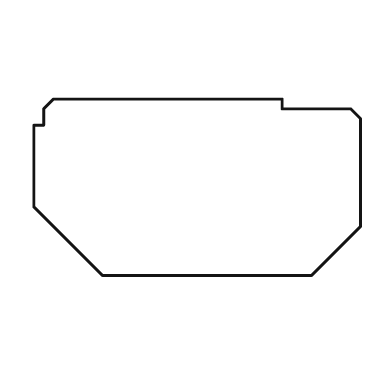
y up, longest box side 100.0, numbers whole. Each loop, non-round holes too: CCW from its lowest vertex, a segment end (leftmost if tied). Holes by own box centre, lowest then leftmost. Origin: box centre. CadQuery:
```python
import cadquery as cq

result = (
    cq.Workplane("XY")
    .moveTo(-29.0, -27.0)
    .lineTo(35.0, -27.0)
    .lineTo(50.0, -12.0)
    .lineTo(50.0, 21.0)
    .lineTo(47.0, 24.0)
    .lineTo(26.0, 24.0)
    .lineTo(26.0, 27.0)
    .lineTo(-44.0, 27.0)
    .lineTo(-47.0, 24.0)
    .lineTo(-47.0, 19.0)
    .lineTo(-50.0, 19.0)
    .lineTo(-50.0, -6.0)
    .close()
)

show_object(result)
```